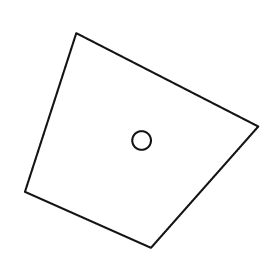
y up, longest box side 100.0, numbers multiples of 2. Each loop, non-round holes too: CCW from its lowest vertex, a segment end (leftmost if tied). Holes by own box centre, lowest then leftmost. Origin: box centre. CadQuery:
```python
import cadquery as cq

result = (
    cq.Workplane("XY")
    .moveTo(4.0, -46.0)
    .lineTo(50.0, 6.0)
    .lineTo(-28.0, 46.0)
    .lineTo(-50.0, -22.0)
    .close()
    .moveTo(0.0, 0.0)
    .circle(4.0)
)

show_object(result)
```